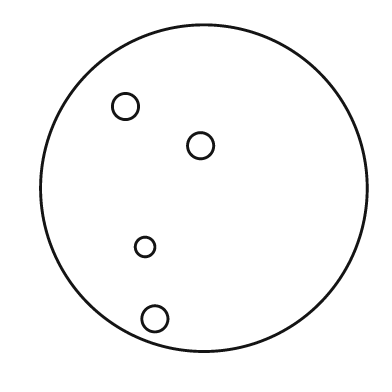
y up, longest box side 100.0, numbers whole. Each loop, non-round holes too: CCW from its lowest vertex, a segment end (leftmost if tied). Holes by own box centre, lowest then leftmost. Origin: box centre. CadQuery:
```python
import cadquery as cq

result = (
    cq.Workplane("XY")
    .moveTo(0.0, 0.0)
    .circle(50.0)
    .moveTo(-15.0, -40.0)
    .circle(4.0)
    .moveTo(-18.0, -18.0)
    .circle(3.0)
    .moveTo(-1.0, 13.0)
    .circle(4.0)
    .moveTo(-24.0, 25.0)
    .circle(4.0)
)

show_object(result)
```